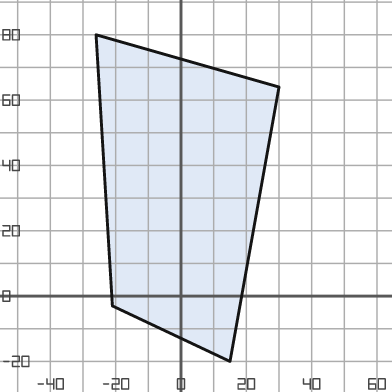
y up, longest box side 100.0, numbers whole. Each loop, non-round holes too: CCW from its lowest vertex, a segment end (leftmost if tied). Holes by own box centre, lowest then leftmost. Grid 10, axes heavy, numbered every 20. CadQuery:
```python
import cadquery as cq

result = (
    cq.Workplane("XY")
    .moveTo(15.0, -20.0)
    .lineTo(30.0, 64.0)
    .lineTo(-26.0, 80.0)
    .lineTo(-21.0, -3.0)
    .close()
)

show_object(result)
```